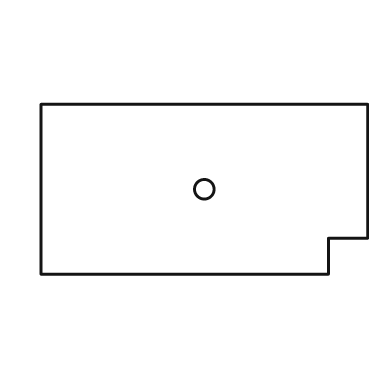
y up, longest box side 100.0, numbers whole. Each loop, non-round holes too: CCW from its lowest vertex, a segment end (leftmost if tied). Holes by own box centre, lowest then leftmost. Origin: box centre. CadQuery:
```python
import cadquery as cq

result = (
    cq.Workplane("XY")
    .moveTo(-50.0, -26.0)
    .lineTo(38.0, -26.0)
    .lineTo(38.0, -15.0)
    .lineTo(50.0, -15.0)
    .lineTo(50.0, 26.0)
    .lineTo(-50.0, 26.0)
    .close()
    .moveTo(0.0, 0.0)
    .circle(3.0)
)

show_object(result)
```